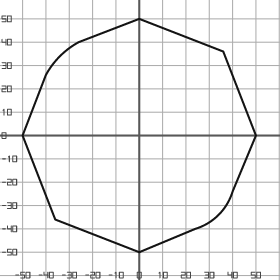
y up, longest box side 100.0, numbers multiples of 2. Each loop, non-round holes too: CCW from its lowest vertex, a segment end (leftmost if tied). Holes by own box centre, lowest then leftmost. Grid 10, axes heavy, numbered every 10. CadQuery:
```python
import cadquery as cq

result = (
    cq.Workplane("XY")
    .moveTo(0.0, -50.0)
    .lineTo(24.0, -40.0)
    .threePointArc((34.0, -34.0), (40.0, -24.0))
    .lineTo(50.0, 0.0)
    .lineTo(36.0, 36.0)
    .lineTo(0.0, 50.0)
    .lineTo(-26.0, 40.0)
    .threePointArc((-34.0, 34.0), (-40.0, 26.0))
    .lineTo(-50.0, 0.0)
    .lineTo(-36.0, -36.0)
    .close()
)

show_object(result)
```